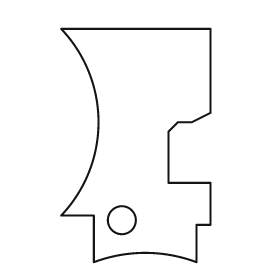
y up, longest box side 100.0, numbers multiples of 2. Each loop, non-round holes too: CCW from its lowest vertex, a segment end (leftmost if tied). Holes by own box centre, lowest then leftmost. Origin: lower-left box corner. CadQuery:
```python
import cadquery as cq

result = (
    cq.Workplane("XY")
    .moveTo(14.0, 0.0)
    .threePointArc((36.0, 4.0), (58.0, 0.0))
    .lineTo(58.0, 16.0)
    .lineTo(64.0, 16.0)
    .lineTo(64.0, 34.0)
    .lineTo(46.0, 34.0)
    .lineTo(46.0, 56.0)
    .lineTo(50.0, 60.0)
    .lineTo(56.0, 60.0)
    .lineTo(64.0, 64.0)
    .lineTo(64.0, 100.0)
    .lineTo(0.0, 100.0)
    .threePointArc((16.0, 60.0), (0.0, 20.0))
    .lineTo(14.0, 20.0)
    .close()
    .moveTo(26.0, 18.0)
    .circle(6.0)
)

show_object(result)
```